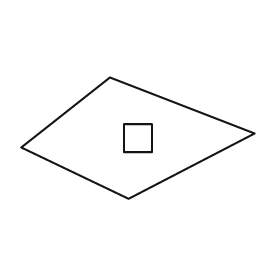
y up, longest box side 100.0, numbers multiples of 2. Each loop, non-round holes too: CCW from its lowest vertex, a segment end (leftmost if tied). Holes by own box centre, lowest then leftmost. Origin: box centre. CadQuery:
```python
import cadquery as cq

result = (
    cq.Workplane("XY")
    .moveTo(-4.0, -26.0)
    .lineTo(50.0, 2.0)
    .lineTo(-12.0, 26.0)
    .lineTo(-50.0, -4.0)
    .close()
    .moveTo(-6.0, -6.0)
    .lineTo(6.0, -6.0)
    .lineTo(6.0, 6.0)
    .lineTo(-6.0, 6.0)
    .close()
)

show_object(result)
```